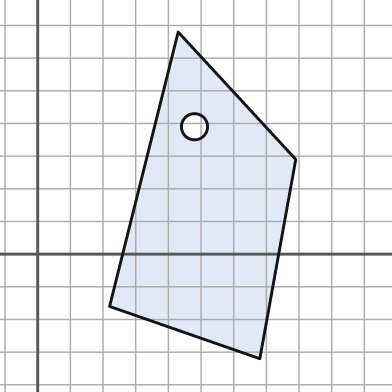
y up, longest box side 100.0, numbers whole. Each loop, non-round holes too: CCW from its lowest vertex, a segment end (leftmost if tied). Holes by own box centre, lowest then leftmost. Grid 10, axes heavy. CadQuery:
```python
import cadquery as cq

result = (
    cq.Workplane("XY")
    .moveTo(68.0, -32.0)
    .lineTo(79.0, 29.0)
    .lineTo(43.0, 68.0)
    .lineTo(22.0, -16.0)
    .close()
    .moveTo(48.0, 39.0)
    .circle(4.0)
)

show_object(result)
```